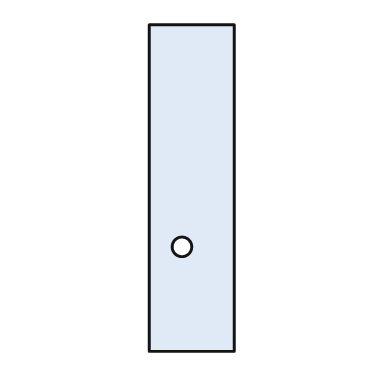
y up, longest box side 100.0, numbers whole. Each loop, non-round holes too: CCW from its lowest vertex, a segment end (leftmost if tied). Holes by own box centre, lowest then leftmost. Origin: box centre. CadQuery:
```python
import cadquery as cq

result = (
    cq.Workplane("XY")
    .moveTo(-13.0, -50.0)
    .lineTo(13.0, -50.0)
    .lineTo(13.0, 50.0)
    .lineTo(-13.0, 50.0)
    .close()
    .moveTo(-3.0, -18.0)
    .circle(3.0)
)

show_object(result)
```